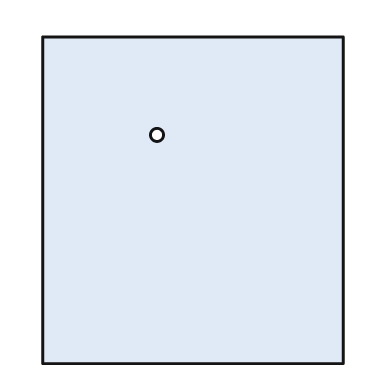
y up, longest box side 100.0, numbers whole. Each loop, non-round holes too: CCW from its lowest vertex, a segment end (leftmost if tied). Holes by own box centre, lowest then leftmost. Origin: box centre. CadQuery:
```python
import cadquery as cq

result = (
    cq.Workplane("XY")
    .moveTo(-46.0, -50.0)
    .lineTo(46.0, -50.0)
    .lineTo(46.0, 50.0)
    .lineTo(-46.0, 50.0)
    .close()
    .moveTo(-11.0, 20.0)
    .circle(2.0)
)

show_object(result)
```